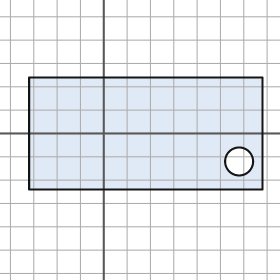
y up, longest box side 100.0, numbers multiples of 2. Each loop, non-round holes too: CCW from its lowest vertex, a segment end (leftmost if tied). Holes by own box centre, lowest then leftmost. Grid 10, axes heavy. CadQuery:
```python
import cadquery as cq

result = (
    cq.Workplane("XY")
    .moveTo(-32.0, -24.0)
    .lineTo(68.0, -24.0)
    .lineTo(68.0, 24.0)
    .lineTo(-32.0, 24.0)
    .close()
    .moveTo(58.0, -12.0)
    .circle(6.0)
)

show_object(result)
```